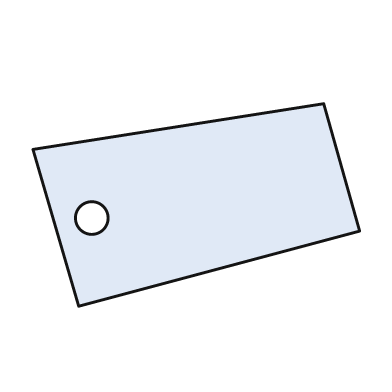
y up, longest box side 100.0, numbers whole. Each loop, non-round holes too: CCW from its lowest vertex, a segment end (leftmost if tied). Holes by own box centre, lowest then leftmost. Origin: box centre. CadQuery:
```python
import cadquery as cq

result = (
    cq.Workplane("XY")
    .moveTo(-36.0, -31.0)
    .lineTo(50.0, -8.0)
    .lineTo(39.0, 31.0)
    .lineTo(-50.0, 17.0)
    .close()
    .moveTo(-32.0, -4.0)
    .circle(5.0)
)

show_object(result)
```